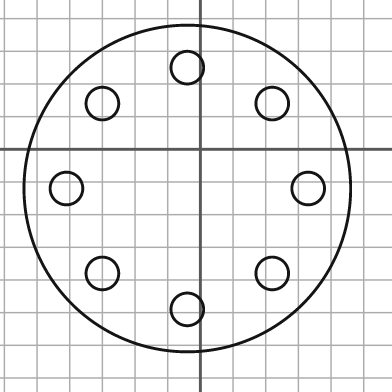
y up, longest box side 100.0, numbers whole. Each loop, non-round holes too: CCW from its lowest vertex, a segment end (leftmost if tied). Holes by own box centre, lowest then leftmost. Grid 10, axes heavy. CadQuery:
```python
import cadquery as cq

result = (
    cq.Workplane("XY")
    .moveTo(-4.0, -12.0)
    .circle(50.0)
    .moveTo(-4.0, -49.0)
    .circle(5.0)
    .moveTo(-30.0, -38.0)
    .circle(5.0)
    .moveTo(22.0, -38.0)
    .circle(5.0)
    .moveTo(-41.0, -12.0)
    .circle(5.0)
    .moveTo(33.0, -12.0)
    .circle(5.0)
    .moveTo(-30.0, 14.0)
    .circle(5.0)
    .moveTo(22.0, 14.0)
    .circle(5.0)
    .moveTo(-4.0, 25.0)
    .circle(5.0)
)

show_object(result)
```